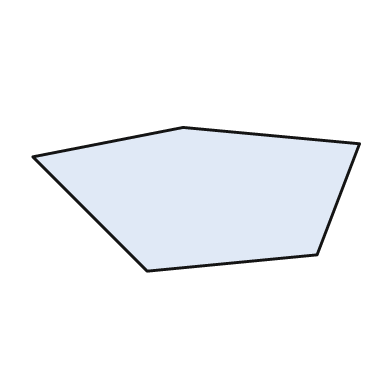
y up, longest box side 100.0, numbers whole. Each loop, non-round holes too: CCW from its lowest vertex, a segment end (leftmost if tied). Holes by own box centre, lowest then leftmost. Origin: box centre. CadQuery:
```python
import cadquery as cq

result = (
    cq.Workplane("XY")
    .moveTo(-15.0, -22.0)
    .lineTo(37.0, -17.0)
    .lineTo(50.0, 17.0)
    .lineTo(-4.0, 22.0)
    .lineTo(-50.0, 13.0)
    .close()
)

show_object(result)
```